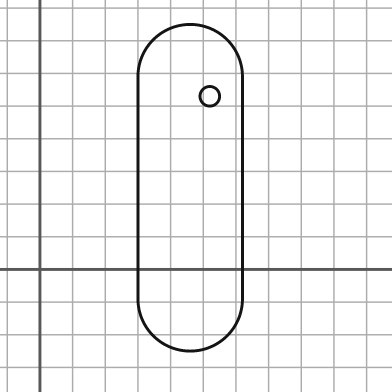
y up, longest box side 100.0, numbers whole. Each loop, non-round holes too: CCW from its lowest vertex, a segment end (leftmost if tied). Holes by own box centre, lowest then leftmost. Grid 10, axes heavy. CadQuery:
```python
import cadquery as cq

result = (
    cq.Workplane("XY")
    .moveTo(30.0, -9.0)
    .threePointArc((46.0, -25.0), (62.0, -9.0))
    .lineTo(62.0, 59.0)
    .threePointArc((46.0, 75.0), (30.0, 59.0))
    .close()
    .moveTo(52.0, 53.0)
    .circle(3.0)
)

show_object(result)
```